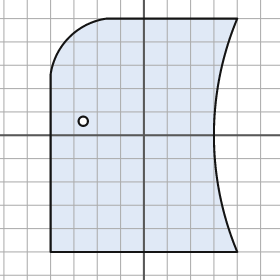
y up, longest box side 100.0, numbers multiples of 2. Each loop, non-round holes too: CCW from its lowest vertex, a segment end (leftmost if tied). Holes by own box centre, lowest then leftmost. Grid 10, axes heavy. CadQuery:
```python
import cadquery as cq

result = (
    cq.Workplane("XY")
    .moveTo(-40.0, -50.0)
    .lineTo(40.0, -50.0)
    .threePointArc((30.0, 0.0), (40.0, 50.0))
    .lineTo(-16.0, 50.0)
    .threePointArc((-32.0, 42.0), (-40.0, 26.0))
    .close()
    .moveTo(-26.0, 6.0)
    .circle(2.0)
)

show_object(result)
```